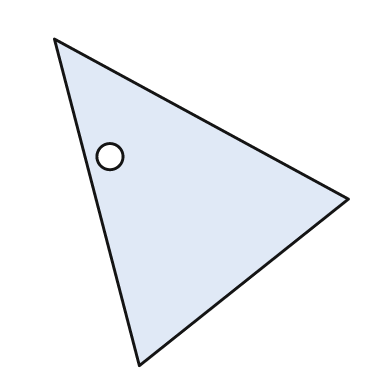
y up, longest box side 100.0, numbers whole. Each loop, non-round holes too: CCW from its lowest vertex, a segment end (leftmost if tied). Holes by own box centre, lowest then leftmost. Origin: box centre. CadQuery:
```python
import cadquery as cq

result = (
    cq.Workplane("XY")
    .moveTo(-19.0, -50.0)
    .lineTo(45.0, 1.0)
    .lineTo(-45.0, 50.0)
    .close()
    .moveTo(-28.0, 14.0)
    .circle(4.0)
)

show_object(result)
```